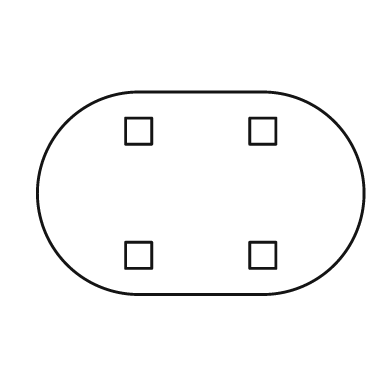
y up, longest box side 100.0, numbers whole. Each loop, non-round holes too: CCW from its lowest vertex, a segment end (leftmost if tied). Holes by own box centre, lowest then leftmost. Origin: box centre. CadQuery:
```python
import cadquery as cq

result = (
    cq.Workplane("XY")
    .moveTo(-19.0, -31.0)
    .lineTo(19.0, -31.0)
    .threePointArc((50.0, 0.0), (19.0, 31.0))
    .lineTo(-19.0, 31.0)
    .threePointArc((-50.0, 0.0), (-19.0, -31.0))
    .close()
    .moveTo(-23.0, -23.0)
    .lineTo(-15.0, -23.0)
    .lineTo(-15.0, -15.0)
    .lineTo(-23.0, -15.0)
    .close()
    .moveTo(15.0, -23.0)
    .lineTo(23.0, -23.0)
    .lineTo(23.0, -15.0)
    .lineTo(15.0, -15.0)
    .close()
    .moveTo(-23.0, 15.0)
    .lineTo(-15.0, 15.0)
    .lineTo(-15.0, 23.0)
    .lineTo(-23.0, 23.0)
    .close()
    .moveTo(15.0, 15.0)
    .lineTo(23.0, 15.0)
    .lineTo(23.0, 23.0)
    .lineTo(15.0, 23.0)
    .close()
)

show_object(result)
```